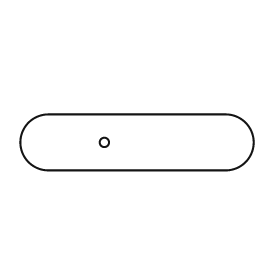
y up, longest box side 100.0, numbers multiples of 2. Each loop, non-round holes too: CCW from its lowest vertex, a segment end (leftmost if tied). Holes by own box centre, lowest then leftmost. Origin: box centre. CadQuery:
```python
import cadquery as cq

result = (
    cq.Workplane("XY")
    .moveTo(-38.0, -12.0)
    .lineTo(38.0, -12.0)
    .threePointArc((50.0, 0.0), (38.0, 12.0))
    .lineTo(-38.0, 12.0)
    .threePointArc((-50.0, 0.0), (-38.0, -12.0))
    .close()
    .moveTo(-14.0, 0.0)
    .circle(2.0)
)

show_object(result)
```